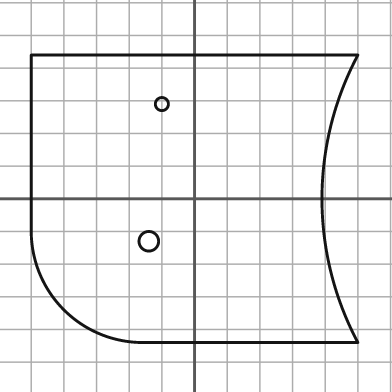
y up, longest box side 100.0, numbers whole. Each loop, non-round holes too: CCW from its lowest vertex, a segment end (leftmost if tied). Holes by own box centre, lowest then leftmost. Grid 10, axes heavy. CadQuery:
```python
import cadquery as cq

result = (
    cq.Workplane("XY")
    .moveTo(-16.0, -44.0)
    .lineTo(50.0, -44.0)
    .threePointArc((39.0, 0.0), (50.0, 44.0))
    .lineTo(-50.0, 44.0)
    .lineTo(-50.0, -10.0)
    .threePointArc((-40.0, -34.0), (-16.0, -44.0))
    .close()
    .moveTo(-14.0, -13.0)
    .circle(3.0)
    .moveTo(-10.0, 29.0)
    .circle(2.0)
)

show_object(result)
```